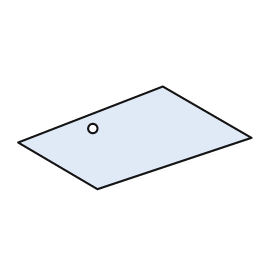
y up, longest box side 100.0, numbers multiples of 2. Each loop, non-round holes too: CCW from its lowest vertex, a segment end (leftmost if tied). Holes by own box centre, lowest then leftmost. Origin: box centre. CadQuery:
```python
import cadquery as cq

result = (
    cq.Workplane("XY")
    .moveTo(-16.0, -22.0)
    .lineTo(50.0, 0.0)
    .lineTo(12.0, 22.0)
    .lineTo(-50.0, -2.0)
    .close()
    .moveTo(-18.0, 4.0)
    .circle(2.0)
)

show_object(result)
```